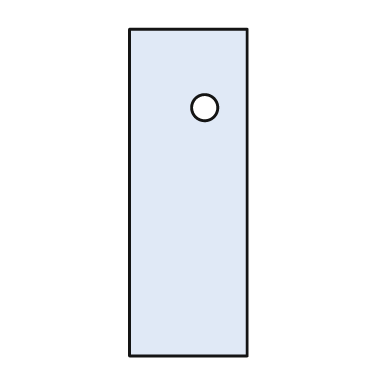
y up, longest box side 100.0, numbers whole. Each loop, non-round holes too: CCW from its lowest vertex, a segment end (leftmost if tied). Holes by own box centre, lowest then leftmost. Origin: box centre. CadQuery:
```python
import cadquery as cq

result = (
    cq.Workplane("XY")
    .moveTo(-18.0, -50.0)
    .lineTo(18.0, -50.0)
    .lineTo(18.0, 50.0)
    .lineTo(-18.0, 50.0)
    .close()
    .moveTo(5.0, 26.0)
    .circle(4.0)
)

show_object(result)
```